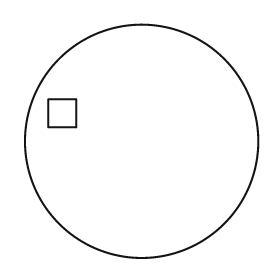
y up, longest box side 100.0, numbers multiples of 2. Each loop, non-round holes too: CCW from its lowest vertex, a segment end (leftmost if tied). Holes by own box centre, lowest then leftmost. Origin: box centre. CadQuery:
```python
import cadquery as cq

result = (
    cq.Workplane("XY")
    .moveTo(0.0, 0.0)
    .circle(50.0)
    .moveTo(-40.0, 6.0)
    .lineTo(-28.0, 6.0)
    .lineTo(-28.0, 18.0)
    .lineTo(-40.0, 18.0)
    .close()
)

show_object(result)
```